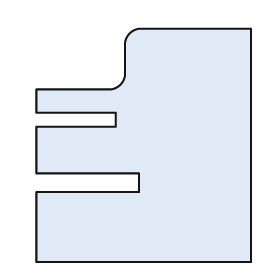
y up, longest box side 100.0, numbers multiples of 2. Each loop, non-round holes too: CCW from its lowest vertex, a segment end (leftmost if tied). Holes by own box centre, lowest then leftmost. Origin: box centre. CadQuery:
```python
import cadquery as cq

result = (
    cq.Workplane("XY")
    .moveTo(-46.0, -50.0)
    .lineTo(46.0, -50.0)
    .lineTo(46.0, 50.0)
    .lineTo(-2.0, 50.0)
    .threePointArc((-6.0, 48.0), (-8.0, 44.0))
    .lineTo(-8.0, 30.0)
    .threePointArc((-10.0, 26.0), (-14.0, 24.0))
    .lineTo(-46.0, 24.0)
    .lineTo(-46.0, 14.0)
    .lineTo(-12.0, 14.0)
    .lineTo(-12.0, 8.0)
    .lineTo(-46.0, 8.0)
    .lineTo(-46.0, -12.0)
    .lineTo(-2.0, -12.0)
    .lineTo(-2.0, -20.0)
    .lineTo(-46.0, -20.0)
    .close()
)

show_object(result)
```